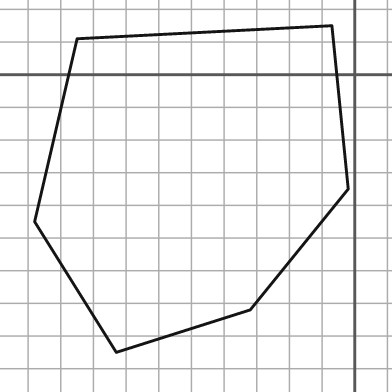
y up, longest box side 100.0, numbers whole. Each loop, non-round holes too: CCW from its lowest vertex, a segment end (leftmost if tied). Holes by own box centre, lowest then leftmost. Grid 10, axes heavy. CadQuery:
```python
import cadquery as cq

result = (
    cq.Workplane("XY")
    .moveTo(-73.0, -85.0)
    .lineTo(-32.0, -72.0)
    .lineTo(-2.0, -35.0)
    .lineTo(-7.0, 15.0)
    .lineTo(-85.0, 11.0)
    .lineTo(-98.0, -45.0)
    .close()
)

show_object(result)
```